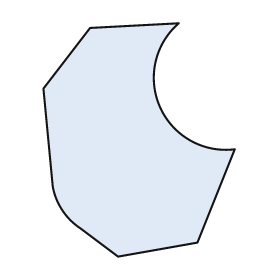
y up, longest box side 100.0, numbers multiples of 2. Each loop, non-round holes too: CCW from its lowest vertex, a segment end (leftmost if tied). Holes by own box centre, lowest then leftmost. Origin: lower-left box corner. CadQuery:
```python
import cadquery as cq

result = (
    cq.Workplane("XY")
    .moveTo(32.0, 0.0)
    .lineTo(66.0, 6.0)
    .lineTo(82.0, 46.0)
    .threePointArc((50.0, 64.0), (58.0, 100.0))
    .lineTo(20.0, 98.0)
    .lineTo(0.0, 72.0)
    .lineTo(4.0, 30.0)
    .threePointArc((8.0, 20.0), (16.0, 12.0))
    .close()
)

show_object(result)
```